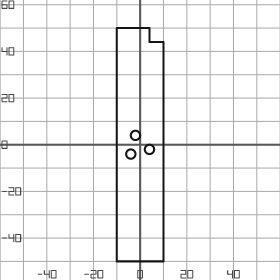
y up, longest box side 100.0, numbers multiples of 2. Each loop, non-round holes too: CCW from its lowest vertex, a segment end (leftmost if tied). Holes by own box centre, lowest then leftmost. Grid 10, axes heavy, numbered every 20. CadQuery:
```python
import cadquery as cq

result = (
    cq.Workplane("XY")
    .moveTo(-10.0, -50.0)
    .lineTo(10.0, -50.0)
    .lineTo(10.0, 44.0)
    .lineTo(4.0, 44.0)
    .lineTo(4.0, 50.0)
    .lineTo(-10.0, 50.0)
    .close()
    .moveTo(-4.0, -4.0)
    .circle(2.0)
    .moveTo(4.0, -2.0)
    .circle(2.0)
    .moveTo(-2.0, 4.0)
    .circle(2.0)
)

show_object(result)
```